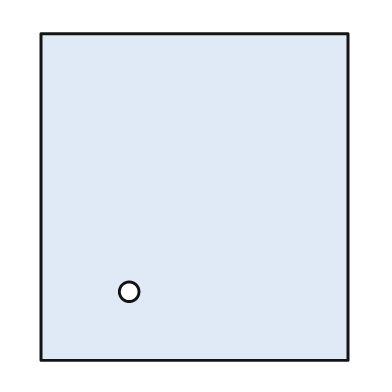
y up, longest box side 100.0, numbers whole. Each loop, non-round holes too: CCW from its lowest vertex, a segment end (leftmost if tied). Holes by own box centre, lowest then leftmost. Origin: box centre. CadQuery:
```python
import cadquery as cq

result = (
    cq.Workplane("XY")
    .moveTo(-47.0, -50.0)
    .lineTo(47.0, -50.0)
    .lineTo(47.0, 50.0)
    .lineTo(-47.0, 50.0)
    .close()
    .moveTo(-20.0, -29.0)
    .circle(3.0)
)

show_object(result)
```